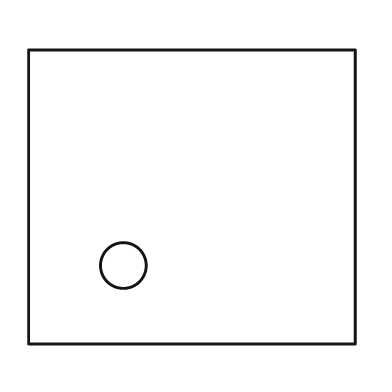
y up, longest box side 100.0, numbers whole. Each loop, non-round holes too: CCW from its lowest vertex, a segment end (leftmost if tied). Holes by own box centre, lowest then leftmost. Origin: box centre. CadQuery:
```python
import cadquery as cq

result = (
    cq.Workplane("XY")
    .moveTo(-50.0, -45.0)
    .lineTo(50.0, -45.0)
    .lineTo(50.0, 45.0)
    .lineTo(-50.0, 45.0)
    .close()
    .moveTo(-21.0, -21.0)
    .circle(7.0)
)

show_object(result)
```